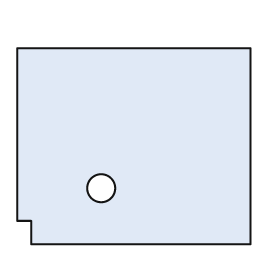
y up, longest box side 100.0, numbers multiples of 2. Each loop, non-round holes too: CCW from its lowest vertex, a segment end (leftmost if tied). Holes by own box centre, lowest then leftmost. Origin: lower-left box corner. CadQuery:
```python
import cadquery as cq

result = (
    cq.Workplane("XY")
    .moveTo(6.0, 0.0)
    .lineTo(100.0, 0.0)
    .lineTo(100.0, 84.0)
    .lineTo(0.0, 84.0)
    .lineTo(0.0, 10.0)
    .lineTo(6.0, 10.0)
    .close()
    .moveTo(36.0, 24.0)
    .circle(6.0)
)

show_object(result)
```